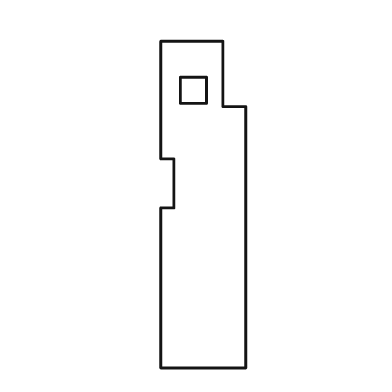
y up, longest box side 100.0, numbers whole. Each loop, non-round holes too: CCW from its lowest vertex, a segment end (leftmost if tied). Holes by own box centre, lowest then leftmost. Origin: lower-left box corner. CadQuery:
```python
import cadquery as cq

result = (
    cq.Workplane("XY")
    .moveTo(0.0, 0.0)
    .lineTo(26.0, 0.0)
    .lineTo(26.0, 80.0)
    .lineTo(19.0, 80.0)
    .lineTo(19.0, 100.0)
    .lineTo(0.0, 100.0)
    .lineTo(0.0, 64.0)
    .lineTo(4.0, 64.0)
    .lineTo(4.0, 49.0)
    .lineTo(0.0, 49.0)
    .close()
    .moveTo(6.0, 81.0)
    .lineTo(14.0, 81.0)
    .lineTo(14.0, 89.0)
    .lineTo(6.0, 89.0)
    .close()
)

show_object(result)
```